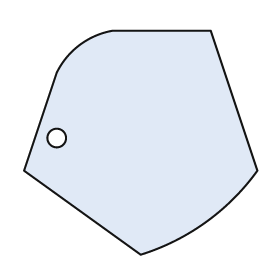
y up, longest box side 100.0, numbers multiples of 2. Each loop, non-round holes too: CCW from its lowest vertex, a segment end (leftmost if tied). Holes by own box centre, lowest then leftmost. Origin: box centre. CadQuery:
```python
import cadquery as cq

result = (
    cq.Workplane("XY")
    .moveTo(0.0, -48.0)
    .threePointArc((28.0, -34.0), (50.0, -12.0))
    .lineTo(30.0, 48.0)
    .lineTo(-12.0, 48.0)
    .threePointArc((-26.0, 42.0), (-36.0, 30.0))
    .lineTo(-50.0, -12.0)
    .close()
    .moveTo(-36.0, 2.0)
    .circle(4.0)
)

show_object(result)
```